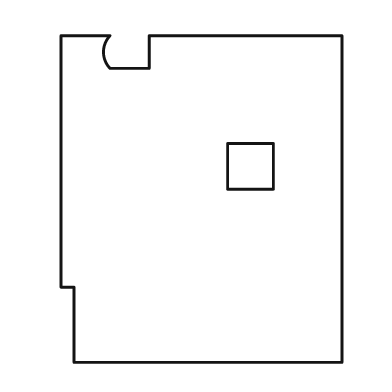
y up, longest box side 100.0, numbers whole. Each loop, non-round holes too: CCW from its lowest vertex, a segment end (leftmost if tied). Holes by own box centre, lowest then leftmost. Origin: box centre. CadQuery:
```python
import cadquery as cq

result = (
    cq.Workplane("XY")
    .moveTo(-39.0, -50.0)
    .lineTo(43.0, -50.0)
    .lineTo(43.0, 50.0)
    .lineTo(-16.0, 50.0)
    .lineTo(-16.0, 40.0)
    .lineTo(-28.0, 40.0)
    .threePointArc((-30.0, 45.0), (-28.0, 50.0))
    .lineTo(-43.0, 50.0)
    .lineTo(-43.0, -27.0)
    .lineTo(-39.0, -27.0)
    .close()
    .moveTo(8.0, 3.0)
    .lineTo(22.0, 3.0)
    .lineTo(22.0, 17.0)
    .lineTo(8.0, 17.0)
    .close()
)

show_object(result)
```